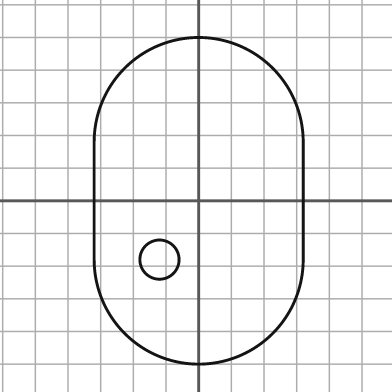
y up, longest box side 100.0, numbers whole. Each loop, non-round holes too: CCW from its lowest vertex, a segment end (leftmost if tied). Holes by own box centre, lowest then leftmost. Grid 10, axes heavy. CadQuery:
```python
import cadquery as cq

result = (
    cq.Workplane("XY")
    .moveTo(-32.0, -18.0)
    .threePointArc((0.0, -50.0), (32.0, -18.0))
    .lineTo(32.0, 18.0)
    .threePointArc((0.0, 50.0), (-32.0, 18.0))
    .close()
    .moveTo(-12.0, -18.0)
    .circle(6.0)
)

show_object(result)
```